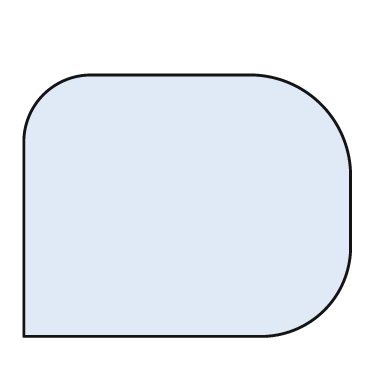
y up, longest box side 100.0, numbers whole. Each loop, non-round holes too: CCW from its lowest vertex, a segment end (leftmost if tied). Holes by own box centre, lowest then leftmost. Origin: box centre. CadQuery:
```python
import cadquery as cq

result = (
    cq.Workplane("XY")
    .moveTo(-50.0, -40.0)
    .lineTo(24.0, -40.0)
    .threePointArc((42.0, -32.0), (50.0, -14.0))
    .lineTo(50.0, 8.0)
    .threePointArc((41.0, 31.0), (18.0, 40.0))
    .lineTo(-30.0, 40.0)
    .threePointArc((-44.0, 34.0), (-50.0, 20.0))
    .close()
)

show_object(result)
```